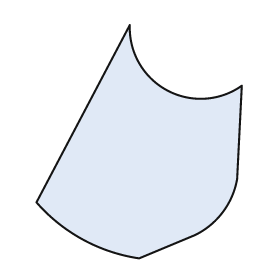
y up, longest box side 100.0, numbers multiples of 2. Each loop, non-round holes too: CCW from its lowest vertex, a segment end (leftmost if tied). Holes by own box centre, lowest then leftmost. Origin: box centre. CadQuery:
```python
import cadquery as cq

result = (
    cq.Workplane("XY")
    .moveTo(0.0, -50.0)
    .lineTo(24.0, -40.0)
    .threePointArc((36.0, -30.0), (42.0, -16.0))
    .lineTo(44.0, 24.0)
    .threePointArc((12.0, 22.0), (-4.0, 50.0))
    .lineTo(-44.0, -26.0)
    .threePointArc((-24.0, -42.0), (0.0, -50.0))
    .close()
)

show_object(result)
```